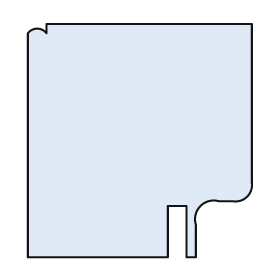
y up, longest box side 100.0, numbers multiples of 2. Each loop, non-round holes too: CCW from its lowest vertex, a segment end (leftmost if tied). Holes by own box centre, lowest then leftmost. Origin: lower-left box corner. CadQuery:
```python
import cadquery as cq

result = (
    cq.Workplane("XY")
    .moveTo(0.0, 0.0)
    .lineTo(60.0, 0.0)
    .lineTo(60.0, 22.0)
    .lineTo(68.0, 22.0)
    .lineTo(68.0, 0.0)
    .lineTo(72.0, 0.0)
    .lineTo(72.0, 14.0)
    .threePointArc((74.0, 22.0), (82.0, 24.0))
    .lineTo(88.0, 24.0)
    .threePointArc((94.0, 26.0), (96.0, 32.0))
    .lineTo(96.0, 100.0)
    .lineTo(8.0, 100.0)
    .lineTo(8.0, 96.0)
    .threePointArc((4.0, 98.0), (0.0, 96.0))
    .close()
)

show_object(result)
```